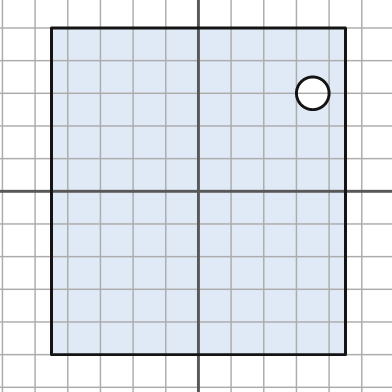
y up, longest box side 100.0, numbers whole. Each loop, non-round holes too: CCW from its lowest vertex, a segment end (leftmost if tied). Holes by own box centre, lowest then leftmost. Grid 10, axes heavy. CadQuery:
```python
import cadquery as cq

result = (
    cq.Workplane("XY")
    .moveTo(-45.0, -50.0)
    .lineTo(45.0, -50.0)
    .lineTo(45.0, 50.0)
    .lineTo(-45.0, 50.0)
    .close()
    .moveTo(35.0, 30.0)
    .circle(5.0)
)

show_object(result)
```